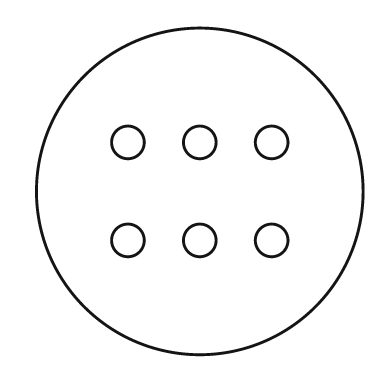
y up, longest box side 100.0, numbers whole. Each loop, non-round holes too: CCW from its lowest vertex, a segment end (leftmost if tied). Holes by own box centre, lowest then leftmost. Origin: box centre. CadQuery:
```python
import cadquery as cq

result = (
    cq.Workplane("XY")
    .moveTo(0.0, 0.0)
    .circle(50.0)
    .moveTo(-22.0, -15.0)
    .circle(5.0)
    .moveTo(0.0, -15.0)
    .circle(5.0)
    .moveTo(22.0, -15.0)
    .circle(5.0)
    .moveTo(-22.0, 15.0)
    .circle(5.0)
    .moveTo(0.0, 15.0)
    .circle(5.0)
    .moveTo(22.0, 15.0)
    .circle(5.0)
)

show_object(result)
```